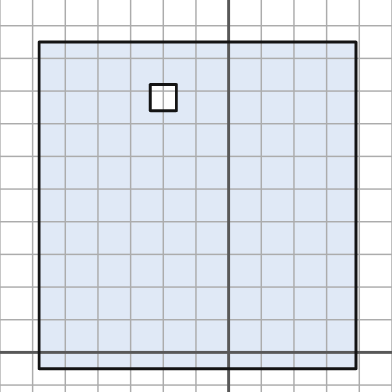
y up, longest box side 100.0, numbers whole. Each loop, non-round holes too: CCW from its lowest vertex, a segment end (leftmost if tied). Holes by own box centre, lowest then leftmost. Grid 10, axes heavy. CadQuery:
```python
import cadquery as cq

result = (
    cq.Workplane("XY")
    .moveTo(-58.0, -5.0)
    .lineTo(39.0, -5.0)
    .lineTo(39.0, 95.0)
    .lineTo(-58.0, 95.0)
    .close()
    .moveTo(-24.0, 74.0)
    .lineTo(-16.0, 74.0)
    .lineTo(-16.0, 82.0)
    .lineTo(-24.0, 82.0)
    .close()
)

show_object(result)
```